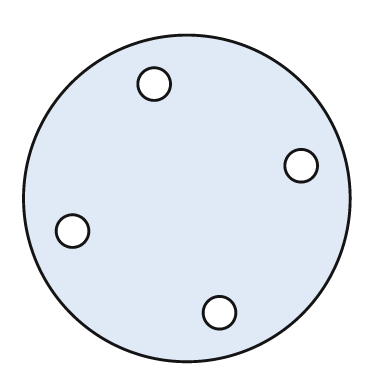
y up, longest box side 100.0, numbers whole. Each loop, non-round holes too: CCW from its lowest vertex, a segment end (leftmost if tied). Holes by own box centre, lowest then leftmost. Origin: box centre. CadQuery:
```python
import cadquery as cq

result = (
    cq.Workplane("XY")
    .moveTo(0.0, 0.0)
    .circle(50.0)
    .moveTo(10.0, -35.0)
    .circle(5.0)
    .moveTo(-35.0, -10.0)
    .circle(5.0)
    .moveTo(35.0, 10.0)
    .circle(5.0)
    .moveTo(-10.0, 35.0)
    .circle(5.0)
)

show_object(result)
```